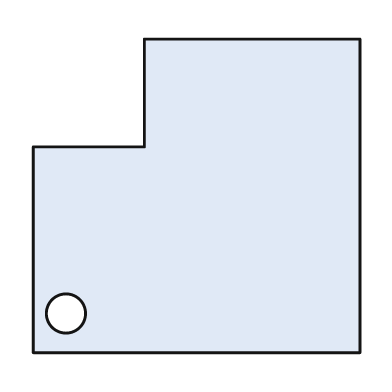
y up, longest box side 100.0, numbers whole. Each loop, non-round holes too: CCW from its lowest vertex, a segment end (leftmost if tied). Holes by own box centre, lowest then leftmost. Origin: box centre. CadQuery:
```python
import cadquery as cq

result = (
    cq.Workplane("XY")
    .moveTo(-50.0, -48.0)
    .lineTo(50.0, -48.0)
    .lineTo(50.0, 48.0)
    .lineTo(-16.0, 48.0)
    .lineTo(-16.0, 15.0)
    .lineTo(-50.0, 15.0)
    .close()
    .moveTo(-40.0, -36.0)
    .circle(6.0)
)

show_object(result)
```